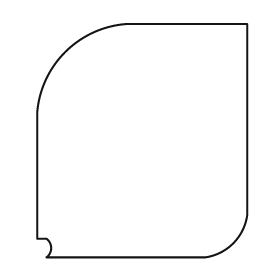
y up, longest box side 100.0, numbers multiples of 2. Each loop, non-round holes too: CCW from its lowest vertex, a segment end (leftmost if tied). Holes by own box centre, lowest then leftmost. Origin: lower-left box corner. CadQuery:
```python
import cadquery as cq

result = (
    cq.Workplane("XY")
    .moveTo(4.0, 0.0)
    .lineTo(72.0, 0.0)
    .threePointArc((84.0, 6.0), (90.0, 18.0))
    .lineTo(90.0, 100.0)
    .lineTo(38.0, 100.0)
    .threePointArc((12.0, 88.0), (0.0, 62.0))
    .lineTo(0.0, 8.0)
    .lineTo(4.0, 8.0)
    .threePointArc((6.0, 4.0), (4.0, 0.0))
    .close()
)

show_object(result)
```